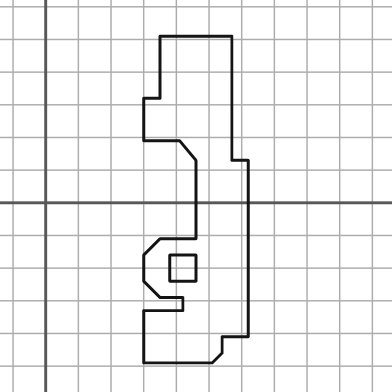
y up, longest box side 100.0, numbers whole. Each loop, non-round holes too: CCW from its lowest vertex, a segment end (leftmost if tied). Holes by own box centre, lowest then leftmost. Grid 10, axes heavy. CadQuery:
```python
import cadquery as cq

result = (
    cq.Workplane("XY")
    .moveTo(30.0, -49.0)
    .lineTo(51.0, -49.0)
    .lineTo(54.0, -46.0)
    .lineTo(54.0, -41.0)
    .lineTo(62.0, -41.0)
    .lineTo(62.0, 13.0)
    .lineTo(57.0, 13.0)
    .lineTo(57.0, 51.0)
    .lineTo(35.0, 51.0)
    .lineTo(35.0, 32.0)
    .lineTo(30.0, 32.0)
    .lineTo(30.0, 19.0)
    .lineTo(41.0, 19.0)
    .lineTo(46.0, 13.0)
    .lineTo(46.0, -11.0)
    .lineTo(35.0, -11.0)
    .lineTo(30.0, -16.0)
    .lineTo(30.0, -24.0)
    .lineTo(35.0, -29.0)
    .lineTo(42.0, -29.0)
    .lineTo(42.0, -33.0)
    .lineTo(30.0, -33.0)
    .close()
    .moveTo(38.0, -24.0)
    .lineTo(46.0, -24.0)
    .lineTo(46.0, -16.0)
    .lineTo(38.0, -16.0)
    .close()
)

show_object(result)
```